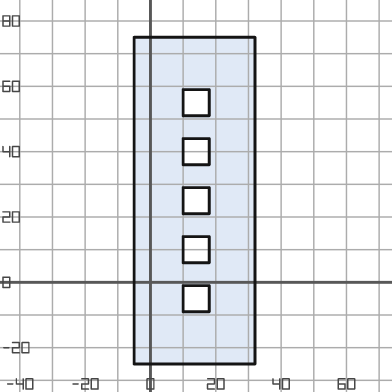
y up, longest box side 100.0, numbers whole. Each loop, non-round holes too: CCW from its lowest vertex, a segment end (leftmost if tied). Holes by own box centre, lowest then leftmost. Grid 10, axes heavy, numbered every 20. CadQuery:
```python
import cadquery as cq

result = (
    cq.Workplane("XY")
    .moveTo(-5.0, -25.0)
    .lineTo(32.0, -25.0)
    .lineTo(32.0, 75.0)
    .lineTo(-5.0, 75.0)
    .close()
    .moveTo(10.0, -9.0)
    .lineTo(18.0, -9.0)
    .lineTo(18.0, -1.0)
    .lineTo(10.0, -1.0)
    .close()
    .moveTo(10.0, 6.0)
    .lineTo(18.0, 6.0)
    .lineTo(18.0, 14.0)
    .lineTo(10.0, 14.0)
    .close()
    .moveTo(10.0, 21.0)
    .lineTo(18.0, 21.0)
    .lineTo(18.0, 29.0)
    .lineTo(10.0, 29.0)
    .close()
    .moveTo(10.0, 36.0)
    .lineTo(18.0, 36.0)
    .lineTo(18.0, 44.0)
    .lineTo(10.0, 44.0)
    .close()
    .moveTo(10.0, 51.0)
    .lineTo(18.0, 51.0)
    .lineTo(18.0, 59.0)
    .lineTo(10.0, 59.0)
    .close()
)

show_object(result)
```